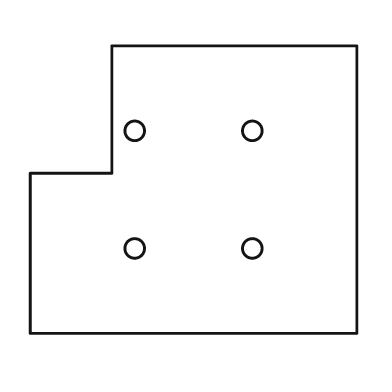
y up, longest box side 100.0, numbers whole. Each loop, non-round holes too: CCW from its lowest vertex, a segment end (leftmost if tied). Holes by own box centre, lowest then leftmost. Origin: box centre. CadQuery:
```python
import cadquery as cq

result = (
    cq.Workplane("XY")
    .moveTo(-50.0, -44.0)
    .lineTo(50.0, -44.0)
    .lineTo(50.0, 44.0)
    .lineTo(-25.0, 44.0)
    .lineTo(-25.0, 5.0)
    .lineTo(-50.0, 5.0)
    .close()
    .moveTo(-18.0, -18.0)
    .circle(3.0)
    .moveTo(18.0, -18.0)
    .circle(3.0)
    .moveTo(-18.0, 18.0)
    .circle(3.0)
    .moveTo(18.0, 18.0)
    .circle(3.0)
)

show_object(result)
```